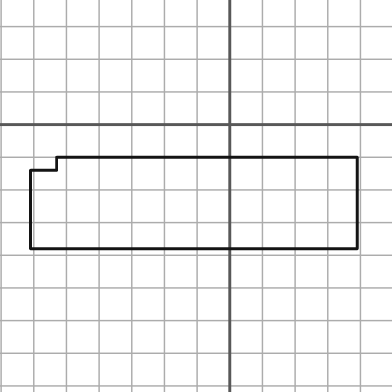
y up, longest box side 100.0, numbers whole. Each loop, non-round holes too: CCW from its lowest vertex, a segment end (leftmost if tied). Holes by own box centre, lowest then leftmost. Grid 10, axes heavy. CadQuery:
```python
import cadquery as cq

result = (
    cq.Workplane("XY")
    .moveTo(-61.0, -38.0)
    .lineTo(39.0, -38.0)
    .lineTo(39.0, -10.0)
    .lineTo(-53.0, -10.0)
    .lineTo(-53.0, -14.0)
    .lineTo(-61.0, -14.0)
    .close()
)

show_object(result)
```